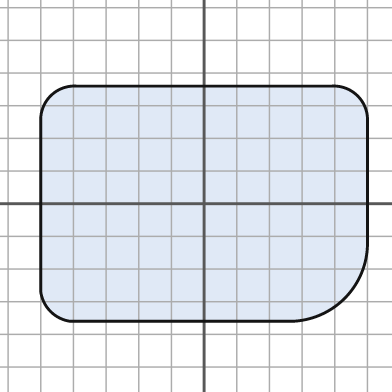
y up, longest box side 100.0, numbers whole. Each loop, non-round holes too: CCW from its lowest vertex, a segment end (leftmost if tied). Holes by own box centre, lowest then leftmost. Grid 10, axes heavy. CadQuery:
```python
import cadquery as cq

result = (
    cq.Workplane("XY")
    .moveTo(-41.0, -36.0)
    .lineTo(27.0, -36.0)
    .threePointArc((43.0, -29.0), (50.0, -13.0))
    .lineTo(50.0, 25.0)
    .threePointArc((47.0, 33.0), (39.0, 36.0))
    .lineTo(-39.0, 36.0)
    .threePointArc((-47.0, 33.0), (-50.0, 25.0))
    .lineTo(-50.0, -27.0)
    .threePointArc((-47.0, -33.0), (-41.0, -36.0))
    .close()
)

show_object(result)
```